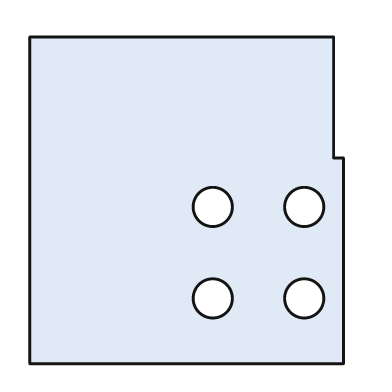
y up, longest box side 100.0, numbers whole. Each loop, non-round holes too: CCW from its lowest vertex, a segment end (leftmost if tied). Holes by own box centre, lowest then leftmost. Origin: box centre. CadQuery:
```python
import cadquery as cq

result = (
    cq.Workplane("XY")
    .moveTo(-48.0, -50.0)
    .lineTo(48.0, -50.0)
    .lineTo(48.0, 13.0)
    .lineTo(45.0, 13.0)
    .lineTo(45.0, 50.0)
    .lineTo(-48.0, 50.0)
    .close()
    .moveTo(8.0, -30.0)
    .circle(6.0)
    .moveTo(36.0, -30.0)
    .circle(6.0)
    .moveTo(8.0, -2.0)
    .circle(6.0)
    .moveTo(36.0, -2.0)
    .circle(6.0)
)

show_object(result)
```